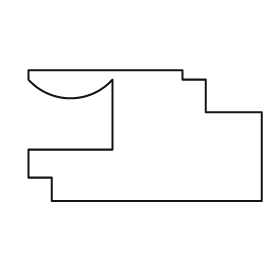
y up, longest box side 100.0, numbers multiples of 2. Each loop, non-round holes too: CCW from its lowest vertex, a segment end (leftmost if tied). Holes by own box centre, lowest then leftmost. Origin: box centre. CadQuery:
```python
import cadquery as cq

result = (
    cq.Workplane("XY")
    .moveTo(-40.0, -28.0)
    .lineTo(50.0, -28.0)
    .lineTo(50.0, 10.0)
    .lineTo(26.0, 10.0)
    .lineTo(26.0, 24.0)
    .lineTo(16.0, 24.0)
    .lineTo(16.0, 28.0)
    .lineTo(-50.0, 28.0)
    .lineTo(-50.0, 24.0)
    .threePointArc((-32.0, 16.0), (-14.0, 24.0))
    .lineTo(-14.0, -6.0)
    .lineTo(-50.0, -6.0)
    .lineTo(-50.0, -18.0)
    .lineTo(-40.0, -18.0)
    .close()
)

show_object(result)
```